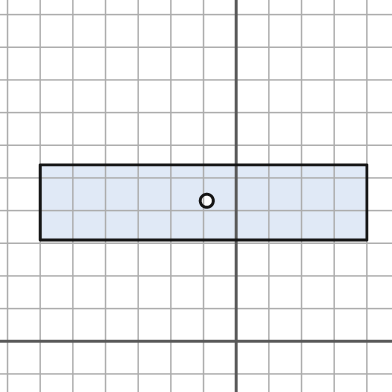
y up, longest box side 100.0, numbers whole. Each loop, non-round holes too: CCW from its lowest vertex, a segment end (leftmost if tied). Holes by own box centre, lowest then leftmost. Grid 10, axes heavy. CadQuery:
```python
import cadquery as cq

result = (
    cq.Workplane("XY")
    .moveTo(-60.0, 31.0)
    .lineTo(40.0, 31.0)
    .lineTo(40.0, 54.0)
    .lineTo(-60.0, 54.0)
    .close()
    .moveTo(-9.0, 43.0)
    .circle(2.0)
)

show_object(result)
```